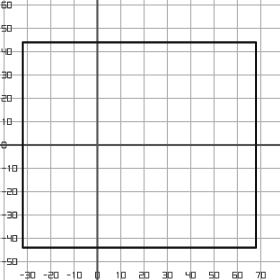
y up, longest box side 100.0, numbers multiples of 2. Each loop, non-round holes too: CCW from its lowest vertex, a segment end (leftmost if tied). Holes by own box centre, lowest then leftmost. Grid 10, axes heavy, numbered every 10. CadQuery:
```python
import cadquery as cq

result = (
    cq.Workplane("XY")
    .moveTo(-32.0, -44.0)
    .lineTo(68.0, -44.0)
    .lineTo(68.0, 44.0)
    .lineTo(-32.0, 44.0)
    .close()
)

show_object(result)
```